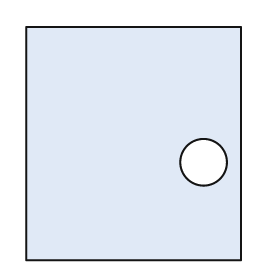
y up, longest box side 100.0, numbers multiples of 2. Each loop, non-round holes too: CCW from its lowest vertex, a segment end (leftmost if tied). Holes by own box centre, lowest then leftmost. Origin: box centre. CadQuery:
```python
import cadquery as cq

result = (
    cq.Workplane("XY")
    .moveTo(-46.0, -50.0)
    .lineTo(46.0, -50.0)
    .lineTo(46.0, 50.0)
    .lineTo(-46.0, 50.0)
    .close()
    .moveTo(30.0, -8.0)
    .circle(10.0)
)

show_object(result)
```